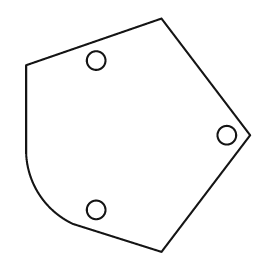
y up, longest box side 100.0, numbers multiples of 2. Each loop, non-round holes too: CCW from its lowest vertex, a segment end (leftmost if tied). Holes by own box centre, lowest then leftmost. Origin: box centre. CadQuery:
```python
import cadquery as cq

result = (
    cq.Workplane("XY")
    .moveTo(10.0, -50.0)
    .lineTo(48.0, 0.0)
    .lineTo(10.0, 50.0)
    .lineTo(-48.0, 30.0)
    .lineTo(-48.0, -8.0)
    .threePointArc((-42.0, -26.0), (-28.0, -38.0))
    .close()
    .moveTo(-18.0, -32.0)
    .circle(4.0)
    .moveTo(38.0, 0.0)
    .circle(4.0)
    .moveTo(-18.0, 32.0)
    .circle(4.0)
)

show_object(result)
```